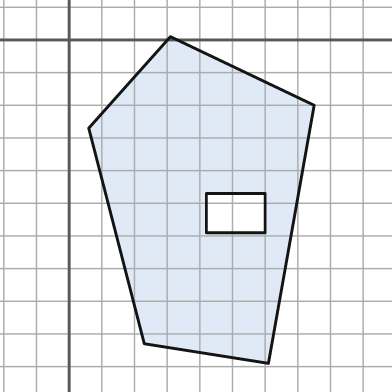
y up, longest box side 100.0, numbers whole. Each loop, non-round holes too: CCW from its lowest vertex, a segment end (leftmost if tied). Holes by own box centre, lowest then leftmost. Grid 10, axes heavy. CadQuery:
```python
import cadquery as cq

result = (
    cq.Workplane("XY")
    .moveTo(61.0, -99.0)
    .lineTo(75.0, -20.0)
    .lineTo(31.0, 1.0)
    .lineTo(6.0, -27.0)
    .lineTo(23.0, -93.0)
    .close()
    .moveTo(42.0, -59.0)
    .lineTo(60.0, -59.0)
    .lineTo(60.0, -47.0)
    .lineTo(42.0, -47.0)
    .close()
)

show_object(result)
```